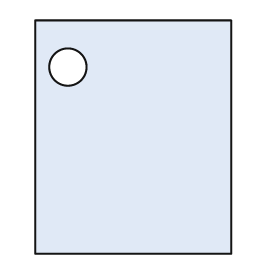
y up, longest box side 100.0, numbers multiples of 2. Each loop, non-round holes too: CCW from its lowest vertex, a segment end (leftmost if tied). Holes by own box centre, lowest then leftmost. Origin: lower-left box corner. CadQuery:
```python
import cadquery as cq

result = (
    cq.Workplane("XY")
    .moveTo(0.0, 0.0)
    .lineTo(84.0, 0.0)
    .lineTo(84.0, 100.0)
    .lineTo(0.0, 100.0)
    .close()
    .moveTo(14.0, 80.0)
    .circle(8.0)
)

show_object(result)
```